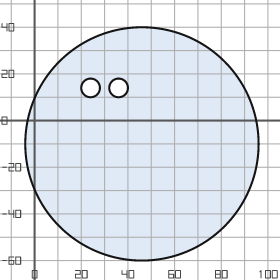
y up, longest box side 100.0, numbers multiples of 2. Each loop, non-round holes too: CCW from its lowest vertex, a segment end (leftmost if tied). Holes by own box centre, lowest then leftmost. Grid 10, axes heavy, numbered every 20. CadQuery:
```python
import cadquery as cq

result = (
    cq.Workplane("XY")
    .moveTo(46.0, -10.0)
    .circle(50.0)
    .moveTo(24.0, 14.0)
    .circle(4.0)
    .moveTo(36.0, 14.0)
    .circle(4.0)
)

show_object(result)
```